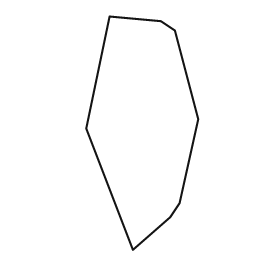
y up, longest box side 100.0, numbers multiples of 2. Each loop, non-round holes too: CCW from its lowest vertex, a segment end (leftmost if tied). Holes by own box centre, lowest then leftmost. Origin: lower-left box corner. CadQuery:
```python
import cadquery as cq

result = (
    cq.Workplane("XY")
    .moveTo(20.0, 0.0)
    .lineTo(36.0, 14.0)
    .lineTo(40.0, 20.0)
    .lineTo(48.0, 56.0)
    .lineTo(38.0, 94.0)
    .lineTo(32.0, 98.0)
    .lineTo(10.0, 100.0)
    .lineTo(0.0, 52.0)
    .close()
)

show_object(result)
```